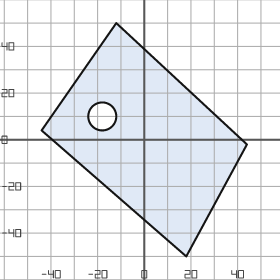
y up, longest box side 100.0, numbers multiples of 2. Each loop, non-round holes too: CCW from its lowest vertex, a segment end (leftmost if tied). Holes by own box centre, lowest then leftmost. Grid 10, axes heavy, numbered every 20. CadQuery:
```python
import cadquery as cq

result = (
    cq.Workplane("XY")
    .moveTo(18.0, -50.0)
    .lineTo(44.0, -2.0)
    .lineTo(-12.0, 50.0)
    .lineTo(-44.0, 4.0)
    .close()
    .moveTo(-18.0, 10.0)
    .circle(6.0)
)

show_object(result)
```